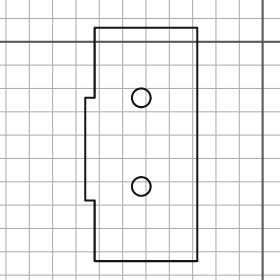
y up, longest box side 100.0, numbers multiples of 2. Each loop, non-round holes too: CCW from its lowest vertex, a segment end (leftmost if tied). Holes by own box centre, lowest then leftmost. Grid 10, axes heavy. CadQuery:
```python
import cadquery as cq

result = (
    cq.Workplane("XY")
    .moveTo(-72.0, -94.0)
    .lineTo(-28.0, -94.0)
    .lineTo(-28.0, 6.0)
    .lineTo(-72.0, 6.0)
    .lineTo(-72.0, -24.0)
    .lineTo(-76.0, -24.0)
    .lineTo(-76.0, -68.0)
    .lineTo(-72.0, -68.0)
    .close()
    .moveTo(-52.0, -62.0)
    .circle(4.0)
    .moveTo(-52.0, -24.0)
    .circle(4.0)
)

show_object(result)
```